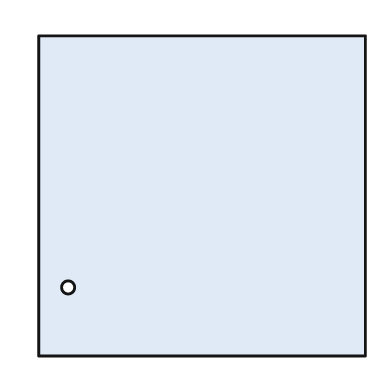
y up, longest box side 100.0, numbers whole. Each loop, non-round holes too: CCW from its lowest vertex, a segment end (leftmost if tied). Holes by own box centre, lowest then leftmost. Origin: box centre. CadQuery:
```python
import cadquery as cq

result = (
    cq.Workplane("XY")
    .moveTo(-50.0, -49.0)
    .lineTo(50.0, -49.0)
    .lineTo(50.0, 49.0)
    .lineTo(-50.0, 49.0)
    .close()
    .moveTo(-41.0, -28.0)
    .circle(2.0)
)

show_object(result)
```